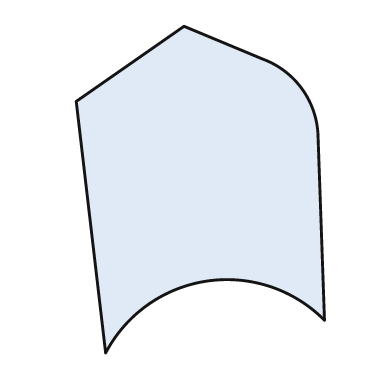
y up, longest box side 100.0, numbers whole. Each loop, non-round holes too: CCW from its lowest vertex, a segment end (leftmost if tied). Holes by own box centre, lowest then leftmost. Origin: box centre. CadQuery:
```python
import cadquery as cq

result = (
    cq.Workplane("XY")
    .moveTo(-29.0, -50.0)
    .threePointArc((2.0, -28.0), (38.0, -40.0))
    .lineTo(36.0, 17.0)
    .threePointArc((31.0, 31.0), (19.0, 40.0))
    .lineTo(-5.0, 50.0)
    .lineTo(-38.0, 27.0)
    .close()
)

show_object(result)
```